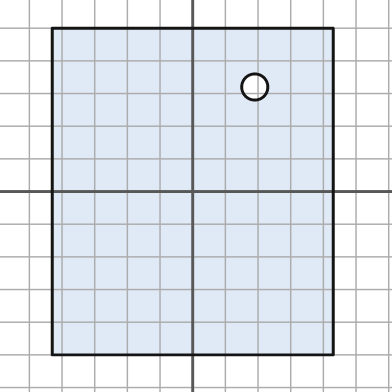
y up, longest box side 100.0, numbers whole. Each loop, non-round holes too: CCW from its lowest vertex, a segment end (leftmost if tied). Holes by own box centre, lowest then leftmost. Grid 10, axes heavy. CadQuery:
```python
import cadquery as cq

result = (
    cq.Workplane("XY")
    .moveTo(-43.0, -50.0)
    .lineTo(43.0, -50.0)
    .lineTo(43.0, 50.0)
    .lineTo(-43.0, 50.0)
    .close()
    .moveTo(19.0, 32.0)
    .circle(4.0)
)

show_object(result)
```